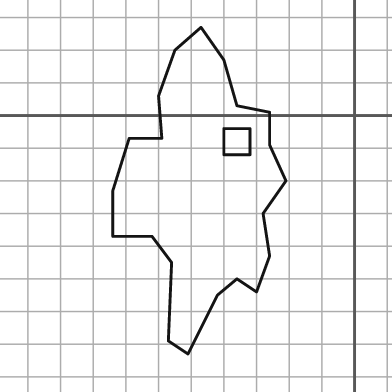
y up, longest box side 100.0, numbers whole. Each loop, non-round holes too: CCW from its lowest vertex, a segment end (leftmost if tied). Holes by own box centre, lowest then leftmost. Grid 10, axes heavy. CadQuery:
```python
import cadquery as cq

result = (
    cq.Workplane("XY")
    .moveTo(-51.0, -73.0)
    .lineTo(-42.0, -55.0)
    .lineTo(-36.0, -50.0)
    .lineTo(-30.0, -54.0)
    .lineTo(-26.0, -43.0)
    .lineTo(-28.0, -30.0)
    .lineTo(-21.0, -20.0)
    .lineTo(-26.0, -9.0)
    .lineTo(-26.0, 1.0)
    .lineTo(-36.0, 3.0)
    .lineTo(-40.0, 17.0)
    .lineTo(-47.0, 27.0)
    .lineTo(-55.0, 20.0)
    .lineTo(-60.0, 6.0)
    .lineTo(-59.0, -7.0)
    .lineTo(-69.0, -7.0)
    .lineTo(-74.0, -23.0)
    .lineTo(-74.0, -37.0)
    .lineTo(-62.0, -37.0)
    .lineTo(-56.0, -45.0)
    .lineTo(-57.0, -69.0)
    .close()
    .moveTo(-40.0, -12.0)
    .lineTo(-32.0, -12.0)
    .lineTo(-32.0, -4.0)
    .lineTo(-40.0, -4.0)
    .close()
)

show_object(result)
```